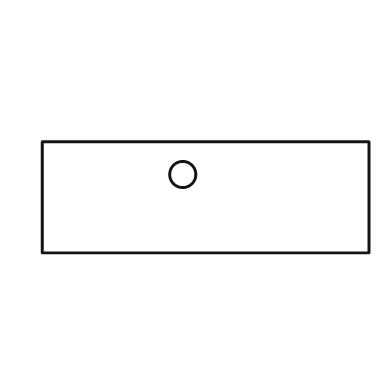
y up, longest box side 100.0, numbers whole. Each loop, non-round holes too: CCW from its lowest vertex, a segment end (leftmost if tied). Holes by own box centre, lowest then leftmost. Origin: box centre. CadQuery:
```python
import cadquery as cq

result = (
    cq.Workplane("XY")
    .moveTo(-50.0, -17.0)
    .lineTo(50.0, -17.0)
    .lineTo(50.0, 17.0)
    .lineTo(-50.0, 17.0)
    .close()
    .moveTo(-7.0, 7.0)
    .circle(4.0)
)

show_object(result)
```